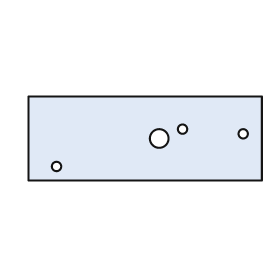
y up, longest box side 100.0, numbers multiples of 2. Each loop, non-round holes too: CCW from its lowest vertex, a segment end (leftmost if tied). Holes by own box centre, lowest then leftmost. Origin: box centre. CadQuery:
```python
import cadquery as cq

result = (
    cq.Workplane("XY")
    .moveTo(-50.0, -18.0)
    .lineTo(50.0, -18.0)
    .lineTo(50.0, 18.0)
    .lineTo(-50.0, 18.0)
    .close()
    .moveTo(-38.0, -12.0)
    .circle(2.0)
    .moveTo(6.0, 0.0)
    .circle(4.0)
    .moveTo(42.0, 2.0)
    .circle(2.0)
    .moveTo(16.0, 4.0)
    .circle(2.0)
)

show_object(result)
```